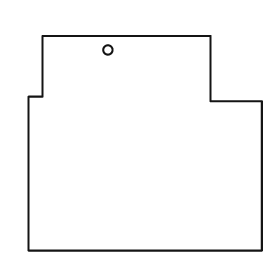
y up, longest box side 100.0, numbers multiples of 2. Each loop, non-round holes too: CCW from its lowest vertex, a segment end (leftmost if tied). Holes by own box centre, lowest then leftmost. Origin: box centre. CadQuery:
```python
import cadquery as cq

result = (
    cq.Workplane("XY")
    .moveTo(-50.0, -46.0)
    .lineTo(50.0, -46.0)
    .lineTo(50.0, 18.0)
    .lineTo(28.0, 18.0)
    .lineTo(28.0, 46.0)
    .lineTo(-44.0, 46.0)
    .lineTo(-44.0, 20.0)
    .lineTo(-50.0, 20.0)
    .close()
    .moveTo(-16.0, 40.0)
    .circle(2.0)
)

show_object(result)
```